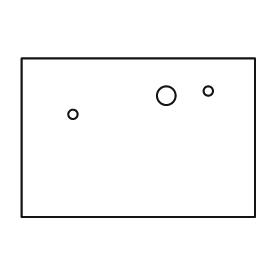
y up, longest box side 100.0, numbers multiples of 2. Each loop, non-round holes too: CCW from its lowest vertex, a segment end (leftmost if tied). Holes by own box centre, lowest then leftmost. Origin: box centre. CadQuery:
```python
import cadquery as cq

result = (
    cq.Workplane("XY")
    .moveTo(-50.0, -34.0)
    .lineTo(50.0, -34.0)
    .lineTo(50.0, 34.0)
    .lineTo(-50.0, 34.0)
    .close()
    .moveTo(-28.0, 10.0)
    .circle(2.0)
    .moveTo(12.0, 18.0)
    .circle(4.0)
    .moveTo(30.0, 20.0)
    .circle(2.0)
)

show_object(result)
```